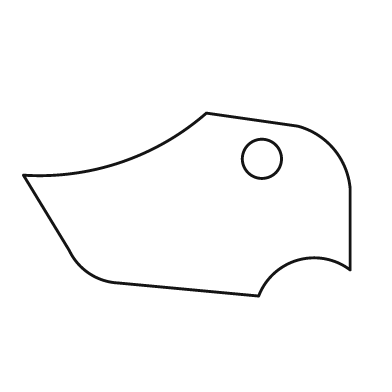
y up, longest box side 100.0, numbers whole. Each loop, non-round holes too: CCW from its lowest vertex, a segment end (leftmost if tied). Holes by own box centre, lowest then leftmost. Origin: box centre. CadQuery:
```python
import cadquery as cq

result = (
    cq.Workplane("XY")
    .moveTo(22.0, -28.0)
    .threePointArc((34.0, -17.0), (50.0, -20.0))
    .lineTo(50.0, 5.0)
    .threePointArc((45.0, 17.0), (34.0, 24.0))
    .lineTo(6.0, 28.0)
    .threePointArc((-20.0, 13.0), (-50.0, 9.0))
    .lineTo(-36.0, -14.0)
    .threePointArc((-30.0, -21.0), (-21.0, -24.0))
    .close()
    .moveTo(23.0, 14.0)
    .circle(6.0)
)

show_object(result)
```